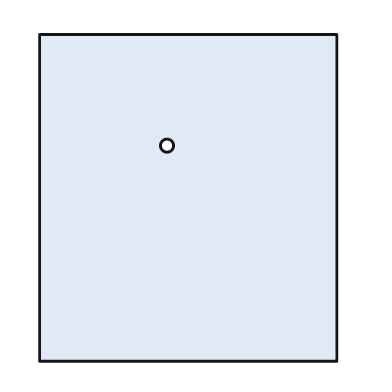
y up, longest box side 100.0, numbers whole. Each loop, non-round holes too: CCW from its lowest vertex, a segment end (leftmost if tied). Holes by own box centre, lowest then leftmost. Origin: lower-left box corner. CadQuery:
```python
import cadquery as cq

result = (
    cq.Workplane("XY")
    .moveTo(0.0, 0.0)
    .lineTo(91.0, 0.0)
    .lineTo(91.0, 100.0)
    .lineTo(0.0, 100.0)
    .close()
    .moveTo(39.0, 66.0)
    .circle(2.0)
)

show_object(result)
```